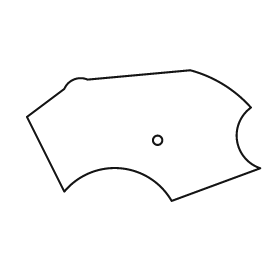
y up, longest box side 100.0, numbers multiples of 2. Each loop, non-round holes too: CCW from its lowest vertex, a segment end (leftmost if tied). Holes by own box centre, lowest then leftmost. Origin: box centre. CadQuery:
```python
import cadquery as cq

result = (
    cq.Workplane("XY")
    .moveTo(12.0, -28.0)
    .lineTo(50.0, -14.0)
    .threePointArc((40.0, -2.0), (46.0, 12.0))
    .threePointArc((34.0, 22.0), (20.0, 28.0))
    .lineTo(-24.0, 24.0)
    .threePointArc((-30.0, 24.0), (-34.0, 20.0))
    .lineTo(-50.0, 8.0)
    .lineTo(-34.0, -24.0)
    .threePointArc((-10.0, -14.0), (12.0, -28.0))
    .close()
    .moveTo(6.0, -2.0)
    .circle(2.0)
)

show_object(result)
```